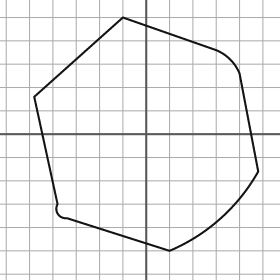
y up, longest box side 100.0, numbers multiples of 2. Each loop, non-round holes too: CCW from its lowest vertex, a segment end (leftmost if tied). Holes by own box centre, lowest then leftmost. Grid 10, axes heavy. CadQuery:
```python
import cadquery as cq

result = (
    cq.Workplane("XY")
    .moveTo(10.0, -50.0)
    .threePointArc((32.0, -36.0), (48.0, -16.0))
    .lineTo(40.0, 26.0)
    .threePointArc((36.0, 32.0), (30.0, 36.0))
    .lineTo(-10.0, 50.0)
    .lineTo(-48.0, 16.0)
    .lineTo(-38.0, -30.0)
    .threePointArc((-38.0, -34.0), (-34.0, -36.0))
    .close()
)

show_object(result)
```